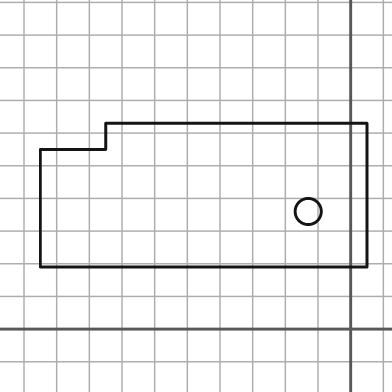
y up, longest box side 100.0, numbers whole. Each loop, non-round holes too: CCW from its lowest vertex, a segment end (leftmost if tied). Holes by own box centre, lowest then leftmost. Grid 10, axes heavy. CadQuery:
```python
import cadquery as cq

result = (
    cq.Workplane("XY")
    .moveTo(-95.0, 19.0)
    .lineTo(5.0, 19.0)
    .lineTo(5.0, 63.0)
    .lineTo(-75.0, 63.0)
    .lineTo(-75.0, 55.0)
    .lineTo(-95.0, 55.0)
    .close()
    .moveTo(-13.0, 36.0)
    .circle(4.0)
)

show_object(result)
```